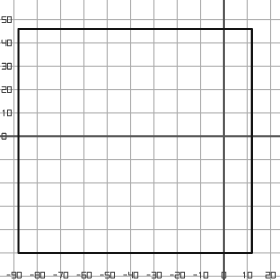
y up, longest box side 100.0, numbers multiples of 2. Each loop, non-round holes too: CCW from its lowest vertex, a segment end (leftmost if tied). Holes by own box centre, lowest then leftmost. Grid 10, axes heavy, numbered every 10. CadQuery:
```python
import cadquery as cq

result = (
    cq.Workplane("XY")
    .moveTo(-88.0, -50.0)
    .lineTo(12.0, -50.0)
    .lineTo(12.0, 46.0)
    .lineTo(-88.0, 46.0)
    .close()
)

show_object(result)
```